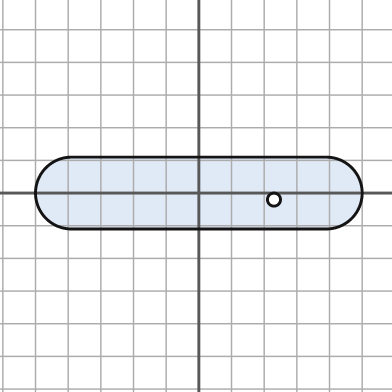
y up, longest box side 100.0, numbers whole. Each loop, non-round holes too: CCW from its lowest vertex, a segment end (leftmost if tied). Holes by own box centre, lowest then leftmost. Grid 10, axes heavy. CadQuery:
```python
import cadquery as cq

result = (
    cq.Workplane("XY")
    .moveTo(-39.0, -11.0)
    .lineTo(39.0, -11.0)
    .threePointArc((50.0, 0.0), (39.0, 11.0))
    .lineTo(-39.0, 11.0)
    .threePointArc((-50.0, 0.0), (-39.0, -11.0))
    .close()
    .moveTo(23.0, -2.0)
    .circle(2.0)
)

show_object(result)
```